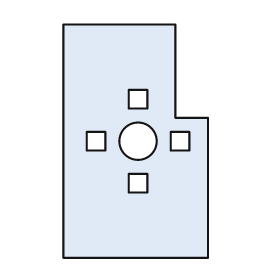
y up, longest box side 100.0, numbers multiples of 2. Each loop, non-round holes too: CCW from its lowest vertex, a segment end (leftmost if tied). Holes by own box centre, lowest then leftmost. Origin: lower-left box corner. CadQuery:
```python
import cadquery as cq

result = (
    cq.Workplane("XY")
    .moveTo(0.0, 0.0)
    .lineTo(62.0, 0.0)
    .lineTo(62.0, 60.0)
    .lineTo(48.0, 60.0)
    .lineTo(48.0, 100.0)
    .lineTo(0.0, 100.0)
    .close()
    .moveTo(28.0, 28.0)
    .lineTo(36.0, 28.0)
    .lineTo(36.0, 36.0)
    .lineTo(28.0, 36.0)
    .close()
    .moveTo(10.0, 46.0)
    .lineTo(18.0, 46.0)
    .lineTo(18.0, 54.0)
    .lineTo(10.0, 54.0)
    .close()
    .moveTo(32.0, 50.0)
    .circle(8.0)
    .moveTo(46.0, 46.0)
    .lineTo(54.0, 46.0)
    .lineTo(54.0, 54.0)
    .lineTo(46.0, 54.0)
    .close()
    .moveTo(28.0, 64.0)
    .lineTo(36.0, 64.0)
    .lineTo(36.0, 72.0)
    .lineTo(28.0, 72.0)
    .close()
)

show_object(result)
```